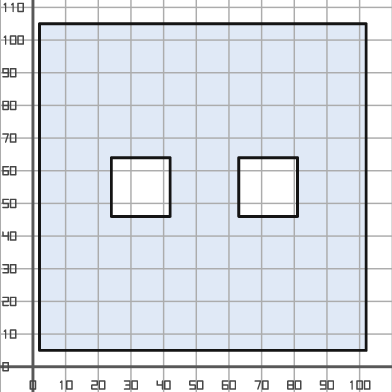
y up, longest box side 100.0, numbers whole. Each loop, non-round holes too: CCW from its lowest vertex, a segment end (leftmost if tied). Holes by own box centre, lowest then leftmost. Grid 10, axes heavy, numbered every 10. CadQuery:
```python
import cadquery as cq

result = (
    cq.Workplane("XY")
    .moveTo(2.0, 5.0)
    .lineTo(102.0, 5.0)
    .lineTo(102.0, 105.0)
    .lineTo(2.0, 105.0)
    .close()
    .moveTo(24.0, 46.0)
    .lineTo(42.0, 46.0)
    .lineTo(42.0, 64.0)
    .lineTo(24.0, 64.0)
    .close()
    .moveTo(63.0, 46.0)
    .lineTo(81.0, 46.0)
    .lineTo(81.0, 64.0)
    .lineTo(63.0, 64.0)
    .close()
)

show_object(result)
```